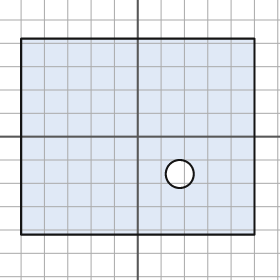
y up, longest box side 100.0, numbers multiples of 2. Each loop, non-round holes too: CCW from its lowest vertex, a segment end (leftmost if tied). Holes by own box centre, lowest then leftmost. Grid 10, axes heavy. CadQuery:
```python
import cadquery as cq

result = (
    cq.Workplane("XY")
    .moveTo(-50.0, -42.0)
    .lineTo(50.0, -42.0)
    .lineTo(50.0, 42.0)
    .lineTo(-50.0, 42.0)
    .close()
    .moveTo(18.0, -16.0)
    .circle(6.0)
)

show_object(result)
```